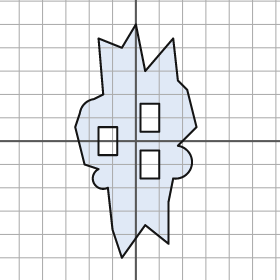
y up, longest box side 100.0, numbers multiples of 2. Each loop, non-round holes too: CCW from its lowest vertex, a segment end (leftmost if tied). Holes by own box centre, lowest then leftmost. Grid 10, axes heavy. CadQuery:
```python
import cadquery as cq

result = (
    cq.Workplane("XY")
    .moveTo(-6.0, -50.0)
    .lineTo(4.0, -36.0)
    .lineTo(14.0, -44.0)
    .lineTo(14.0, -26.0)
    .lineTo(16.0, -16.0)
    .threePointArc((24.0, -10.0), (18.0, -2.0))
    .lineTo(26.0, 6.0)
    .lineTo(22.0, 22.0)
    .lineTo(18.0, 26.0)
    .lineTo(16.0, 44.0)
    .lineTo(4.0, 30.0)
    .lineTo(0.0, 50.0)
    .lineTo(-6.0, 40.0)
    .lineTo(-16.0, 44.0)
    .lineTo(-14.0, 20.0)
    .lineTo(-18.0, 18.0)
    .threePointArc((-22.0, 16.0), (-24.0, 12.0))
    .lineTo(-26.0, 6.0)
    .lineTo(-22.0, -10.0)
    .lineTo(-16.0, -12.0)
    .threePointArc((-18.0, -18.0), (-12.0, -20.0))
    .lineTo(-10.0, -38.0)
    .close()
    .moveTo(2.0, -16.0)
    .lineTo(10.0, -16.0)
    .lineTo(10.0, -4.0)
    .lineTo(2.0, -4.0)
    .close()
    .moveTo(-16.0, -6.0)
    .lineTo(-8.0, -6.0)
    .lineTo(-8.0, 6.0)
    .lineTo(-16.0, 6.0)
    .close()
    .moveTo(2.0, 4.0)
    .lineTo(10.0, 4.0)
    .lineTo(10.0, 16.0)
    .lineTo(2.0, 16.0)
    .close()
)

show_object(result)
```